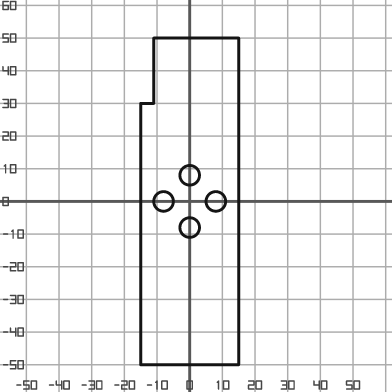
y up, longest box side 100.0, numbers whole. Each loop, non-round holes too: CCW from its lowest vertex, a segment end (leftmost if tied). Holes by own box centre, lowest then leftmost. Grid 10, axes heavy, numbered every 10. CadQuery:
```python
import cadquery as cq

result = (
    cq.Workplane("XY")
    .moveTo(-15.0, -50.0)
    .lineTo(15.0, -50.0)
    .lineTo(15.0, 50.0)
    .lineTo(-11.0, 50.0)
    .lineTo(-11.0, 30.0)
    .lineTo(-15.0, 30.0)
    .close()
    .moveTo(0.0, -8.0)
    .circle(3.0)
    .moveTo(-8.0, 0.0)
    .circle(3.0)
    .moveTo(8.0, 0.0)
    .circle(3.0)
    .moveTo(0.0, 8.0)
    .circle(3.0)
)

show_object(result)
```